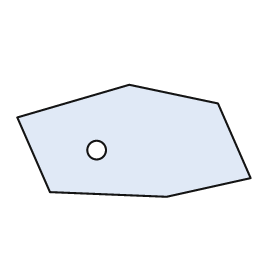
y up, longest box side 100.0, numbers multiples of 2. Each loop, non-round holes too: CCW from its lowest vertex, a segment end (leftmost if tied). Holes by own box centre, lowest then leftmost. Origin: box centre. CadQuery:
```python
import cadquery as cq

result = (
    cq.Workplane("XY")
    .moveTo(14.0, -24.0)
    .lineTo(50.0, -16.0)
    .lineTo(36.0, 16.0)
    .lineTo(-2.0, 24.0)
    .lineTo(-50.0, 10.0)
    .lineTo(-36.0, -22.0)
    .close()
    .moveTo(-16.0, -4.0)
    .circle(4.0)
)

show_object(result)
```